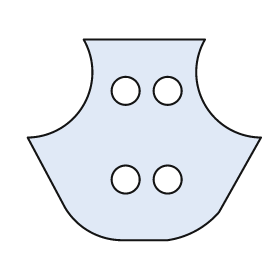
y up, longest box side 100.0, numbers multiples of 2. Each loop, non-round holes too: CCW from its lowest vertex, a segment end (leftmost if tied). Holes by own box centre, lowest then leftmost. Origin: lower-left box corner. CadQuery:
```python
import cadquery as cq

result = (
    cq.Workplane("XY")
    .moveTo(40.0, 0.0)
    .lineTo(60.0, 0.0)
    .threePointArc((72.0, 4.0), (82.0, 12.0))
    .lineTo(100.0, 44.0)
    .threePointArc((76.0, 58.0), (76.0, 86.0))
    .lineTo(24.0, 86.0)
    .threePointArc((24.0, 58.0), (0.0, 44.0))
    .lineTo(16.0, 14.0)
    .threePointArc((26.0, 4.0), (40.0, 0.0))
    .close()
    .moveTo(42.0, 26.0)
    .circle(6.0)
    .moveTo(60.0, 26.0)
    .circle(6.0)
    .moveTo(42.0, 64.0)
    .circle(6.0)
    .moveTo(60.0, 64.0)
    .circle(6.0)
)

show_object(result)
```